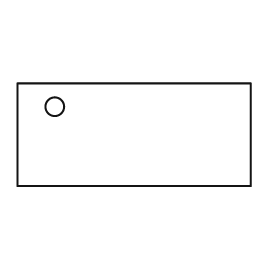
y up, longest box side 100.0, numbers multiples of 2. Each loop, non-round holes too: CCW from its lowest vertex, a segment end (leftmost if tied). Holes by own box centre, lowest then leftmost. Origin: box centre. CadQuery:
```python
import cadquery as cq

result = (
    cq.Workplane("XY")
    .moveTo(-50.0, -22.0)
    .lineTo(50.0, -22.0)
    .lineTo(50.0, 22.0)
    .lineTo(-50.0, 22.0)
    .close()
    .moveTo(-34.0, 12.0)
    .circle(4.0)
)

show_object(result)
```